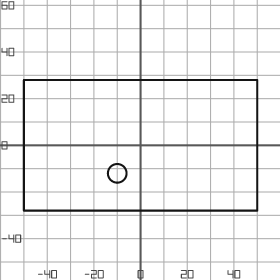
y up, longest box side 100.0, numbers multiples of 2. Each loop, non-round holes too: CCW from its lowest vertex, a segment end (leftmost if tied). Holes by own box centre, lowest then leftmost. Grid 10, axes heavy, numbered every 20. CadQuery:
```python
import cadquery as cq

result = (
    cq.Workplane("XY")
    .moveTo(-50.0, -28.0)
    .lineTo(50.0, -28.0)
    .lineTo(50.0, 28.0)
    .lineTo(-50.0, 28.0)
    .close()
    .moveTo(-10.0, -12.0)
    .circle(4.0)
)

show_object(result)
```